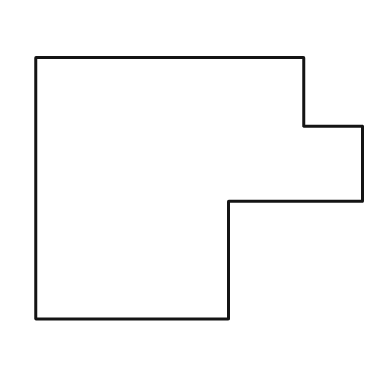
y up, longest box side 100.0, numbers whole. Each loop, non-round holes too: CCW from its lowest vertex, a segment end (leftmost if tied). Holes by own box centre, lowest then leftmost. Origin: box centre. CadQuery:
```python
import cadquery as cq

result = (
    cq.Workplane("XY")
    .moveTo(-50.0, -40.0)
    .lineTo(9.0, -40.0)
    .lineTo(9.0, -4.0)
    .lineTo(50.0, -4.0)
    .lineTo(50.0, 19.0)
    .lineTo(32.0, 19.0)
    .lineTo(32.0, 40.0)
    .lineTo(-50.0, 40.0)
    .close()
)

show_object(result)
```